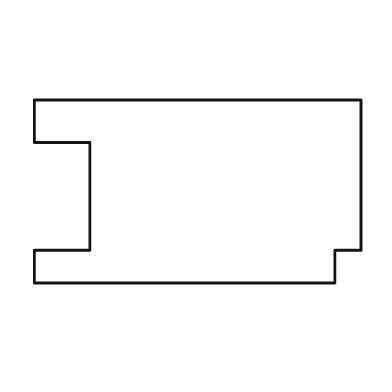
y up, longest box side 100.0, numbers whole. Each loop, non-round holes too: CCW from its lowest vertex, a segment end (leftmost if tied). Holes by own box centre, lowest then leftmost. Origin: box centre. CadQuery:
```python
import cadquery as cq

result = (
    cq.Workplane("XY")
    .moveTo(-50.0, -28.0)
    .lineTo(42.0, -28.0)
    .lineTo(42.0, -18.0)
    .lineTo(50.0, -18.0)
    .lineTo(50.0, 28.0)
    .lineTo(-50.0, 28.0)
    .lineTo(-50.0, 15.0)
    .lineTo(-33.0, 15.0)
    .lineTo(-33.0, -18.0)
    .lineTo(-50.0, -18.0)
    .close()
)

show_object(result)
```